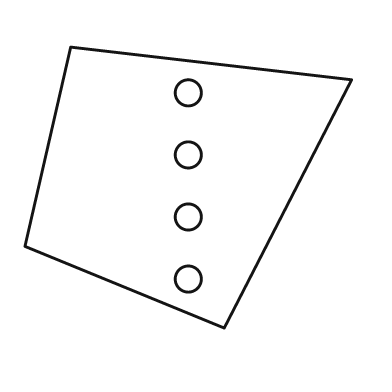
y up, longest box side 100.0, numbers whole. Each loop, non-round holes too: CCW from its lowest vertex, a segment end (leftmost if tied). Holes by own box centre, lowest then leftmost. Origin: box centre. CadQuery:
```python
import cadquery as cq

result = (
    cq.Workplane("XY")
    .moveTo(11.0, -43.0)
    .lineTo(50.0, 33.0)
    .lineTo(-36.0, 43.0)
    .lineTo(-50.0, -18.0)
    .close()
    .moveTo(0.0, -28.0)
    .circle(4.0)
    .moveTo(0.0, -9.0)
    .circle(4.0)
    .moveTo(0.0, 10.0)
    .circle(4.0)
    .moveTo(0.0, 29.0)
    .circle(4.0)
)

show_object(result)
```